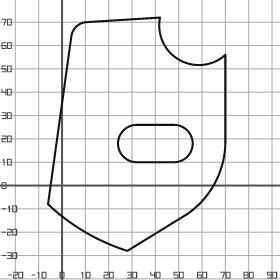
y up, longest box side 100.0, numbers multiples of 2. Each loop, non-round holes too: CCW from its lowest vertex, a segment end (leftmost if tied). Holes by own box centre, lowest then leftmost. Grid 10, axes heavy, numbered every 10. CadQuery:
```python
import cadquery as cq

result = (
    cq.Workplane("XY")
    .moveTo(28.0, -28.0)
    .lineTo(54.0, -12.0)
    .threePointArc((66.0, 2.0), (70.0, 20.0))
    .lineTo(70.0, 56.0)
    .threePointArc((50.0, 54.0), (42.0, 72.0))
    .lineTo(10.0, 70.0)
    .threePointArc((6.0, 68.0), (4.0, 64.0))
    .lineTo(-6.0, -8.0)
    .threePointArc((10.0, -20.0), (28.0, -28.0))
    .close()
    .moveTo(32.0, 10.0)
    .lineTo(48.0, 10.0)
    .threePointArc((56.0, 18.0), (48.0, 26.0))
    .lineTo(32.0, 26.0)
    .threePointArc((24.0, 18.0), (32.0, 10.0))
    .close()
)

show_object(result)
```